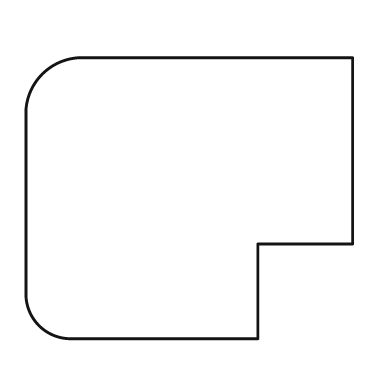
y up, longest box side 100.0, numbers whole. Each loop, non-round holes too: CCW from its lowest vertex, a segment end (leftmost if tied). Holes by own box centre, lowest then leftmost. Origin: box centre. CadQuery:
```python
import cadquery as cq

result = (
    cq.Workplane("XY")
    .moveTo(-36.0, -43.0)
    .lineTo(21.0, -43.0)
    .lineTo(21.0, -14.0)
    .lineTo(50.0, -14.0)
    .lineTo(50.0, 43.0)
    .lineTo(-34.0, 43.0)
    .threePointArc((-45.0, 38.0), (-50.0, 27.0))
    .lineTo(-50.0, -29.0)
    .threePointArc((-46.0, -39.0), (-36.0, -43.0))
    .close()
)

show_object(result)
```